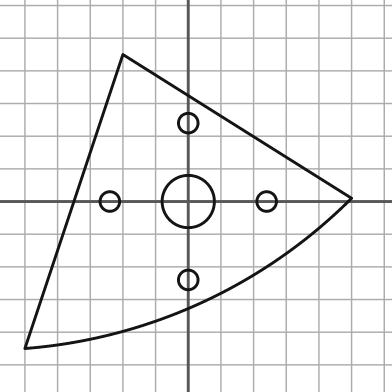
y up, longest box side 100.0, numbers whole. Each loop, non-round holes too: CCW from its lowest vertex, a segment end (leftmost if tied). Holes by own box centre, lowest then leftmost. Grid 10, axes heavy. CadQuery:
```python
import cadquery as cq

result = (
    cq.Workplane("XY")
    .moveTo(-50.0, -45.0)
    .threePointArc((4.0, -31.0), (50.0, 1.0))
    .lineTo(-20.0, 45.0)
    .close()
    .moveTo(0.0, -24.0)
    .circle(3.0)
    .moveTo(-24.0, 0.0)
    .circle(3.0)
    .moveTo(0.0, 0.0)
    .circle(8.0)
    .moveTo(24.0, 0.0)
    .circle(3.0)
    .moveTo(0.0, 24.0)
    .circle(3.0)
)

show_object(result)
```